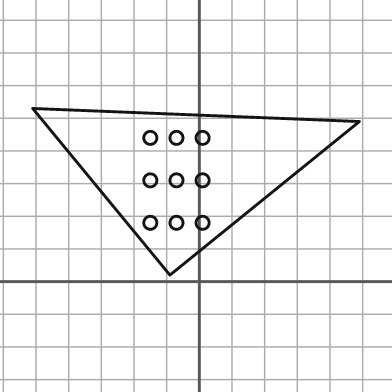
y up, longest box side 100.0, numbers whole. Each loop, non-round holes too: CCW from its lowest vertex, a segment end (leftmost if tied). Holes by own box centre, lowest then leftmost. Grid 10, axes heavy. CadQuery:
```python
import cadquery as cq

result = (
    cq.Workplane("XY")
    .moveTo(-9.0, 2.0)
    .lineTo(49.0, 49.0)
    .lineTo(-51.0, 53.0)
    .close()
    .moveTo(-15.0, 18.0)
    .circle(2.0)
    .moveTo(-7.0, 18.0)
    .circle(2.0)
    .moveTo(1.0, 18.0)
    .circle(2.0)
    .moveTo(-15.0, 31.0)
    .circle(2.0)
    .moveTo(-7.0, 31.0)
    .circle(2.0)
    .moveTo(1.0, 31.0)
    .circle(2.0)
    .moveTo(-15.0, 44.0)
    .circle(2.0)
    .moveTo(-7.0, 44.0)
    .circle(2.0)
    .moveTo(1.0, 44.0)
    .circle(2.0)
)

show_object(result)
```